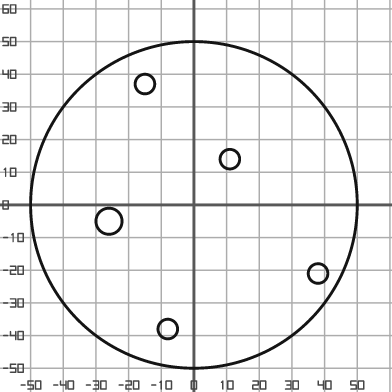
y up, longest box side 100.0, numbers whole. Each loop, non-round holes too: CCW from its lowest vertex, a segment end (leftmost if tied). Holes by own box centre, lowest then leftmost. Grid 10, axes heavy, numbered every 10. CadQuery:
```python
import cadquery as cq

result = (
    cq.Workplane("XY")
    .moveTo(0.0, 0.0)
    .circle(50.0)
    .moveTo(-8.0, -38.0)
    .circle(3.0)
    .moveTo(38.0, -21.0)
    .circle(3.0)
    .moveTo(-26.0, -5.0)
    .circle(4.0)
    .moveTo(11.0, 14.0)
    .circle(3.0)
    .moveTo(-15.0, 37.0)
    .circle(3.0)
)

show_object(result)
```